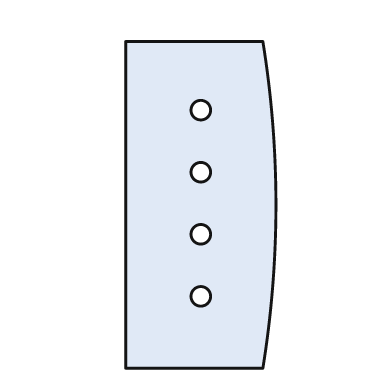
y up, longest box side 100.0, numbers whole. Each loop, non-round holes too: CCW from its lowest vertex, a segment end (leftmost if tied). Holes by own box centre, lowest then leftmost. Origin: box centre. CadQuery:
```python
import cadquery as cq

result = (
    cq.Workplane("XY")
    .moveTo(-23.0, -50.0)
    .lineTo(19.0, -50.0)
    .threePointArc((23.0, 0.0), (19.0, 50.0))
    .lineTo(-23.0, 50.0)
    .close()
    .moveTo(0.0, -28.0)
    .circle(3.0)
    .moveTo(0.0, -9.0)
    .circle(3.0)
    .moveTo(0.0, 10.0)
    .circle(3.0)
    .moveTo(0.0, 29.0)
    .circle(3.0)
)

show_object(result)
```